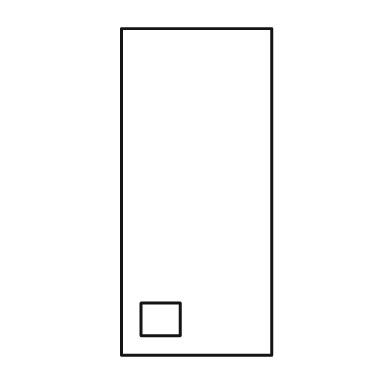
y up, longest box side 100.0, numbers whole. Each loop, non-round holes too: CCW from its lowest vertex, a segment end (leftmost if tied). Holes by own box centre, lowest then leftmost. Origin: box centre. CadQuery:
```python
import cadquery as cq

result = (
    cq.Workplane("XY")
    .moveTo(-23.0, -50.0)
    .lineTo(23.0, -50.0)
    .lineTo(23.0, 50.0)
    .lineTo(-23.0, 50.0)
    .close()
    .moveTo(-17.0, -44.0)
    .lineTo(-5.0, -44.0)
    .lineTo(-5.0, -34.0)
    .lineTo(-17.0, -34.0)
    .close()
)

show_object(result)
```